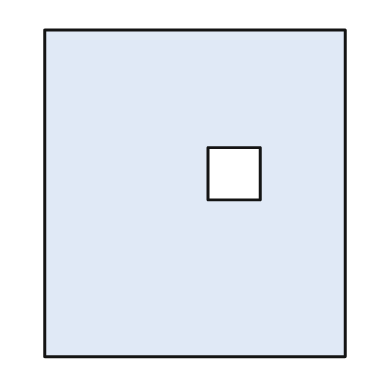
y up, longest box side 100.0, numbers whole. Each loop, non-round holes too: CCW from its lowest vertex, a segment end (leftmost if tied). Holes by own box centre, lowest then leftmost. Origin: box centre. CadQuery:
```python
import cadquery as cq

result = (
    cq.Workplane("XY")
    .moveTo(-46.0, -50.0)
    .lineTo(46.0, -50.0)
    .lineTo(46.0, 50.0)
    .lineTo(-46.0, 50.0)
    .close()
    .moveTo(4.0, -2.0)
    .lineTo(20.0, -2.0)
    .lineTo(20.0, 14.0)
    .lineTo(4.0, 14.0)
    .close()
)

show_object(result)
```